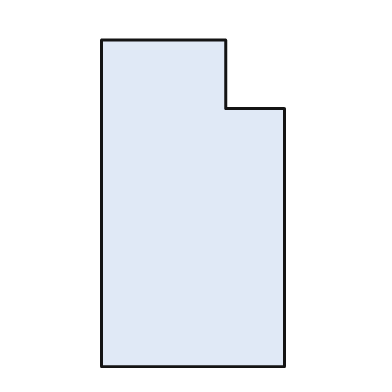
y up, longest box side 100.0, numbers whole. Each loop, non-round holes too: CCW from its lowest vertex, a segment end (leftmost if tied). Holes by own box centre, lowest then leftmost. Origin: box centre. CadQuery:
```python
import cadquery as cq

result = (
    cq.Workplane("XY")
    .moveTo(-28.0, -50.0)
    .lineTo(28.0, -50.0)
    .lineTo(28.0, 29.0)
    .lineTo(10.0, 29.0)
    .lineTo(10.0, 50.0)
    .lineTo(-28.0, 50.0)
    .close()
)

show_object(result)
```